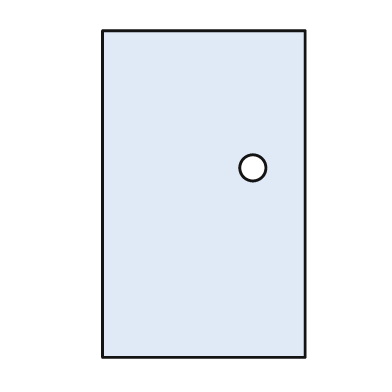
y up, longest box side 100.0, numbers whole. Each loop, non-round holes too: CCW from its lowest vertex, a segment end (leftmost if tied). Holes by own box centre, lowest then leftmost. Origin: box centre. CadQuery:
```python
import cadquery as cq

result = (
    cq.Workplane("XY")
    .moveTo(-31.0, -50.0)
    .lineTo(31.0, -50.0)
    .lineTo(31.0, 50.0)
    .lineTo(-31.0, 50.0)
    .close()
    .moveTo(15.0, 8.0)
    .circle(4.0)
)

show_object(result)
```